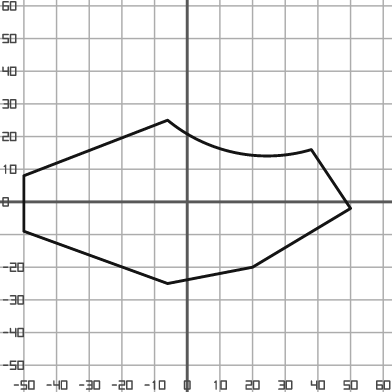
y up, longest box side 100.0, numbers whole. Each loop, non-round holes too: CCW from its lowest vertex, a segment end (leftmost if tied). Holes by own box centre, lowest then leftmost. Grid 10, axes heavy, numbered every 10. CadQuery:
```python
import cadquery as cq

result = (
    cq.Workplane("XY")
    .moveTo(-6.0, -25.0)
    .lineTo(20.0, -20.0)
    .lineTo(50.0, -2.0)
    .lineTo(38.0, 16.0)
    .threePointArc((15.0, 15.0), (-6.0, 25.0))
    .lineTo(-50.0, 8.0)
    .lineTo(-50.0, -9.0)
    .close()
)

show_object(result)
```